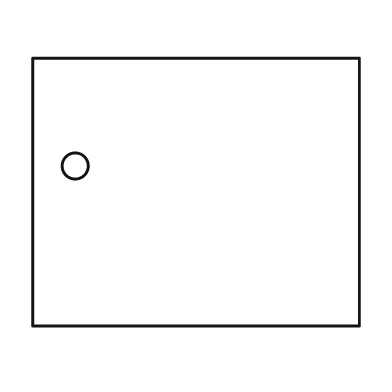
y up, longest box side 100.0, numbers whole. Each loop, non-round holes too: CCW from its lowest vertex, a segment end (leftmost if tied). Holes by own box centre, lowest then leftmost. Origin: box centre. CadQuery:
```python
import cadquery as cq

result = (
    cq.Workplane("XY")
    .moveTo(-50.0, -41.0)
    .lineTo(50.0, -41.0)
    .lineTo(50.0, 41.0)
    .lineTo(-50.0, 41.0)
    .close()
    .moveTo(-37.0, 8.0)
    .circle(4.0)
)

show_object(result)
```